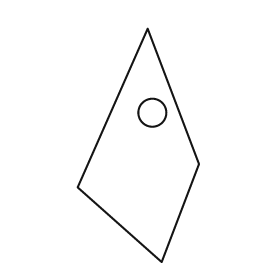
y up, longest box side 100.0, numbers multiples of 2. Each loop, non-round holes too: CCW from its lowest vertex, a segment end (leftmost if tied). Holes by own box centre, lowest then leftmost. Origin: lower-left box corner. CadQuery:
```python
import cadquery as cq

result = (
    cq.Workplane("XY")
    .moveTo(36.0, 0.0)
    .lineTo(52.0, 42.0)
    .lineTo(30.0, 100.0)
    .lineTo(0.0, 32.0)
    .close()
    .moveTo(32.0, 64.0)
    .circle(6.0)
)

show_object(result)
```